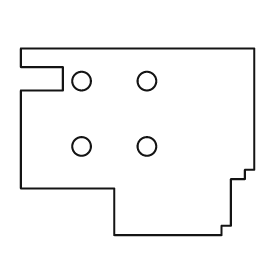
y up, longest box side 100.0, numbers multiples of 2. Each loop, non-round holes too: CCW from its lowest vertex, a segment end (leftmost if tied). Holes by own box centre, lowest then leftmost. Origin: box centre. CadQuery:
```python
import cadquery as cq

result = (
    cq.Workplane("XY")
    .moveTo(-10.0, -40.0)
    .lineTo(36.0, -40.0)
    .lineTo(36.0, -36.0)
    .lineTo(40.0, -36.0)
    .lineTo(40.0, -16.0)
    .lineTo(46.0, -16.0)
    .lineTo(46.0, -12.0)
    .lineTo(50.0, -12.0)
    .lineTo(50.0, 40.0)
    .lineTo(-50.0, 40.0)
    .lineTo(-50.0, 32.0)
    .lineTo(-32.0, 32.0)
    .lineTo(-32.0, 22.0)
    .lineTo(-50.0, 22.0)
    .lineTo(-50.0, -20.0)
    .lineTo(-10.0, -20.0)
    .close()
    .moveTo(-24.0, -2.0)
    .circle(4.0)
    .moveTo(4.0, -2.0)
    .circle(4.0)
    .moveTo(-24.0, 26.0)
    .circle(4.0)
    .moveTo(4.0, 26.0)
    .circle(4.0)
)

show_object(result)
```